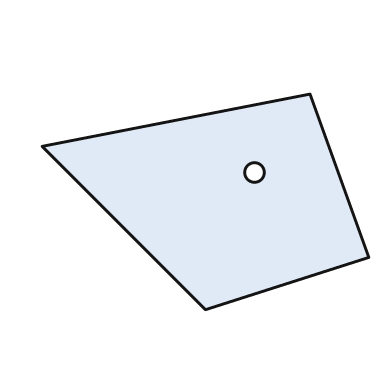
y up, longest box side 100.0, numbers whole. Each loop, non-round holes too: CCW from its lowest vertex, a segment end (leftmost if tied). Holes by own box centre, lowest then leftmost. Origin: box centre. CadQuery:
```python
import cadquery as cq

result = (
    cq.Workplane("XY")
    .moveTo(0.0, -33.0)
    .lineTo(50.0, -17.0)
    .lineTo(32.0, 33.0)
    .lineTo(-50.0, 17.0)
    .close()
    .moveTo(15.0, 9.0)
    .circle(3.0)
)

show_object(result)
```